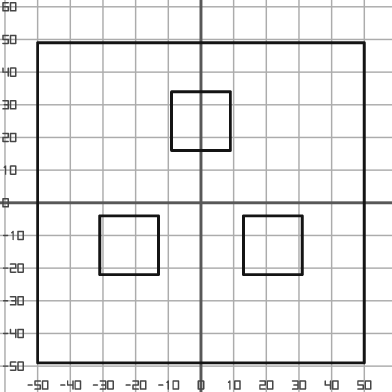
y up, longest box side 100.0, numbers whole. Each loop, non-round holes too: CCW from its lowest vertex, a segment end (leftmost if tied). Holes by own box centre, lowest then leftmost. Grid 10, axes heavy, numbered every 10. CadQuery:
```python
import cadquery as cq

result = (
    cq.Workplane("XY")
    .moveTo(-50.0, -49.0)
    .lineTo(50.0, -49.0)
    .lineTo(50.0, 49.0)
    .lineTo(-50.0, 49.0)
    .close()
    .moveTo(-31.0, -22.0)
    .lineTo(-13.0, -22.0)
    .lineTo(-13.0, -4.0)
    .lineTo(-31.0, -4.0)
    .close()
    .moveTo(13.0, -22.0)
    .lineTo(31.0, -22.0)
    .lineTo(31.0, -4.0)
    .lineTo(13.0, -4.0)
    .close()
    .moveTo(-9.0, 16.0)
    .lineTo(9.0, 16.0)
    .lineTo(9.0, 34.0)
    .lineTo(-9.0, 34.0)
    .close()
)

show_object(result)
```